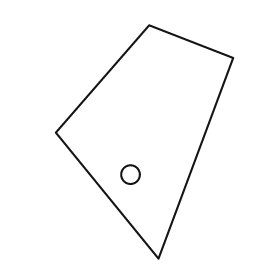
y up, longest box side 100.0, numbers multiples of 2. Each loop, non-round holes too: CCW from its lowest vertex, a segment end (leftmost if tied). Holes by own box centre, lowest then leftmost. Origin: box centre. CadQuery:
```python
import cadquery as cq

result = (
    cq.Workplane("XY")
    .moveTo(6.0, -50.0)
    .lineTo(38.0, 36.0)
    .lineTo(2.0, 50.0)
    .lineTo(-38.0, 4.0)
    .close()
    .moveTo(-6.0, -14.0)
    .circle(4.0)
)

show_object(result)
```